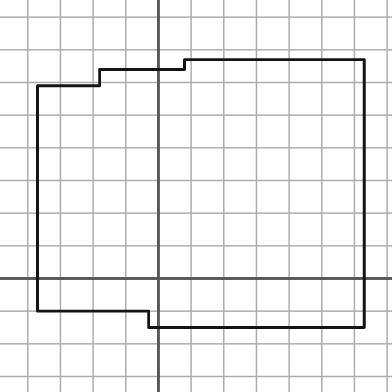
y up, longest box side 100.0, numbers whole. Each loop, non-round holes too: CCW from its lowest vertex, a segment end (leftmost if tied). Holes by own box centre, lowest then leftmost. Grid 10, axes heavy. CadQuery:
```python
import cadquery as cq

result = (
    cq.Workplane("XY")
    .moveTo(-3.0, -15.0)
    .lineTo(63.0, -15.0)
    .lineTo(63.0, 67.0)
    .lineTo(8.0, 67.0)
    .lineTo(8.0, 64.0)
    .lineTo(-18.0, 64.0)
    .lineTo(-18.0, 59.0)
    .lineTo(-37.0, 59.0)
    .lineTo(-37.0, -10.0)
    .lineTo(-3.0, -10.0)
    .close()
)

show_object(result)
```